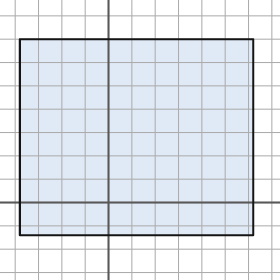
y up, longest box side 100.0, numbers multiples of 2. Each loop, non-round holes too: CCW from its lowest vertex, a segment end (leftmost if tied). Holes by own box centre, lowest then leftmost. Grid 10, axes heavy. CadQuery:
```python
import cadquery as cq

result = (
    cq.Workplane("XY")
    .moveTo(-38.0, -14.0)
    .lineTo(62.0, -14.0)
    .lineTo(62.0, 70.0)
    .lineTo(-38.0, 70.0)
    .close()
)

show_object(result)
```